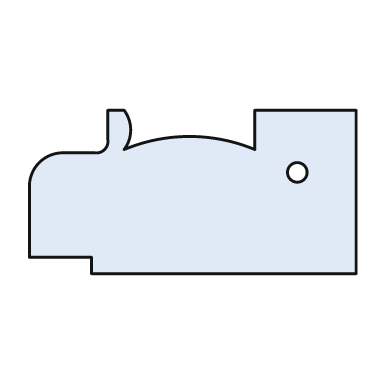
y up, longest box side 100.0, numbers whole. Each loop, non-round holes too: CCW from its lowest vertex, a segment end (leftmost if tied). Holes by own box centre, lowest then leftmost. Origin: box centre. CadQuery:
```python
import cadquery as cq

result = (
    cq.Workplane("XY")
    .moveTo(-31.0, -25.0)
    .lineTo(50.0, -25.0)
    .lineTo(50.0, 25.0)
    .lineTo(19.0, 25.0)
    .lineTo(19.0, 13.0)
    .threePointArc((-1.0, 17.0), (-21.0, 13.0))
    .threePointArc((-19.0, 19.0), (-21.0, 25.0))
    .lineTo(-26.0, 25.0)
    .lineTo(-26.0, 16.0)
    .threePointArc((-27.0, 13.0), (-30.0, 12.0))
    .lineTo(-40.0, 12.0)
    .threePointArc((-47.0, 9.0), (-50.0, 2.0))
    .lineTo(-50.0, -20.0)
    .lineTo(-31.0, -20.0)
    .close()
    .moveTo(32.0, 6.0)
    .circle(3.0)
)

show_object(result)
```